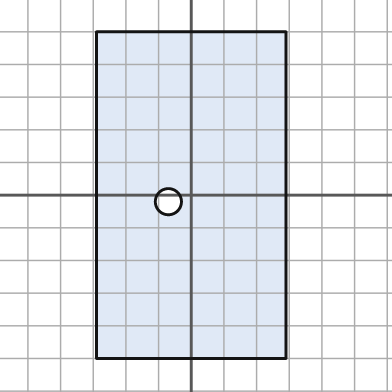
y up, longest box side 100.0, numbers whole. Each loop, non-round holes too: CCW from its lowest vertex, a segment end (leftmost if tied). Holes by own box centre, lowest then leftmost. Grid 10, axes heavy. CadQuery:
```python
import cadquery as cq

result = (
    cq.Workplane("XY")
    .moveTo(-29.0, -50.0)
    .lineTo(29.0, -50.0)
    .lineTo(29.0, 50.0)
    .lineTo(-29.0, 50.0)
    .close()
    .moveTo(-7.0, -2.0)
    .circle(4.0)
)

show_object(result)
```